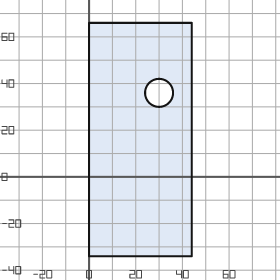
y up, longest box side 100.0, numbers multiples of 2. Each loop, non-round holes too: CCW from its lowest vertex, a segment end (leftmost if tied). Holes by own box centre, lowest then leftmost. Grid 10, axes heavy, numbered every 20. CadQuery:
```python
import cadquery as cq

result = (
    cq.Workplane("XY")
    .moveTo(0.0, -34.0)
    .lineTo(44.0, -34.0)
    .lineTo(44.0, 66.0)
    .lineTo(0.0, 66.0)
    .close()
    .moveTo(30.0, 36.0)
    .circle(6.0)
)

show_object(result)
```